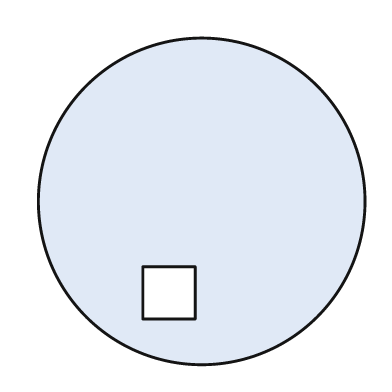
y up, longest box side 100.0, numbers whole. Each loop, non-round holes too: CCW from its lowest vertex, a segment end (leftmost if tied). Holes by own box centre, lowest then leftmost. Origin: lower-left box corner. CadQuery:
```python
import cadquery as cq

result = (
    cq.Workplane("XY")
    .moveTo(50.0, 50.0)
    .circle(50.0)
    .moveTo(32.0, 14.0)
    .lineTo(48.0, 14.0)
    .lineTo(48.0, 30.0)
    .lineTo(32.0, 30.0)
    .close()
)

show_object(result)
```